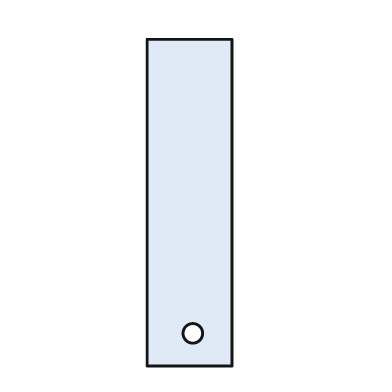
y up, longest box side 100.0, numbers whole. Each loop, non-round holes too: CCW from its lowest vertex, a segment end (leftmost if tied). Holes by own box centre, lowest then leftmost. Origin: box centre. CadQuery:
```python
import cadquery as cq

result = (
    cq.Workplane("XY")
    .moveTo(-13.0, -50.0)
    .lineTo(13.0, -50.0)
    .lineTo(13.0, 50.0)
    .lineTo(-13.0, 50.0)
    .close()
    .moveTo(1.0, -40.0)
    .circle(3.0)
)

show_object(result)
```